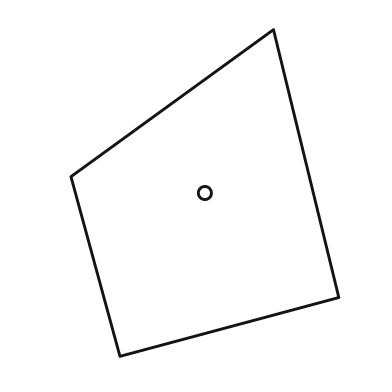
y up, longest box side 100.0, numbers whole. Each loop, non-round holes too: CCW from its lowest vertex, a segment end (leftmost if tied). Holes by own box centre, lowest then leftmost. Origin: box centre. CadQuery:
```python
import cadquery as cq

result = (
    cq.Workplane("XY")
    .moveTo(-26.0, -50.0)
    .lineTo(41.0, -32.0)
    .lineTo(21.0, 50.0)
    .lineTo(-41.0, 5.0)
    .close()
    .moveTo(0.0, 0.0)
    .circle(2.0)
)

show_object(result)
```